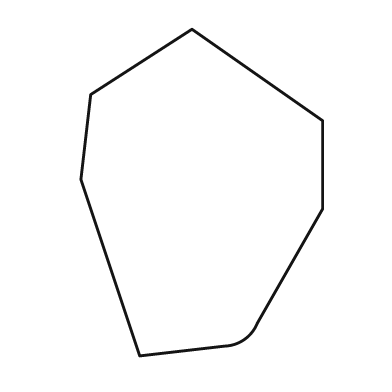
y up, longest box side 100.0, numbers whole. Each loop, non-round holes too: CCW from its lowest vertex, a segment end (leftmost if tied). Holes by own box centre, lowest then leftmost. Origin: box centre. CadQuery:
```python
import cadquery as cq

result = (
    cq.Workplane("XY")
    .moveTo(-19.0, -50.0)
    .lineTo(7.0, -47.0)
    .threePointArc((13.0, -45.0), (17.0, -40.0))
    .lineTo(37.0, -5.0)
    .lineTo(37.0, 22.0)
    .lineTo(-3.0, 50.0)
    .lineTo(-34.0, 30.0)
    .lineTo(-37.0, 4.0)
    .close()
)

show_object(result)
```